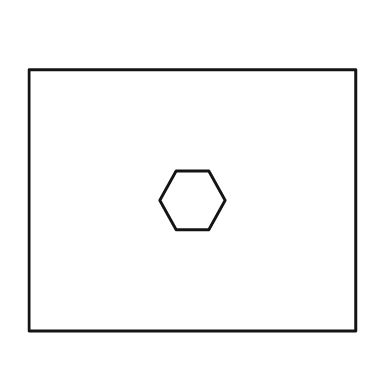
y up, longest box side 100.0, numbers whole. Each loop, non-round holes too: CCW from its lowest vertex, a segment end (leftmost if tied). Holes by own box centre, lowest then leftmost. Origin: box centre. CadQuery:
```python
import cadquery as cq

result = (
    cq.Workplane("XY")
    .moveTo(-50.0, -40.0)
    .lineTo(50.0, -40.0)
    .lineTo(50.0, 40.0)
    .lineTo(-50.0, 40.0)
    .close()
    .moveTo(-5.0, -9.0)
    .lineTo(5.0, -9.0)
    .lineTo(10.0, 0.0)
    .lineTo(5.0, 9.0)
    .lineTo(-5.0, 9.0)
    .lineTo(-10.0, 0.0)
    .close()
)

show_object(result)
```